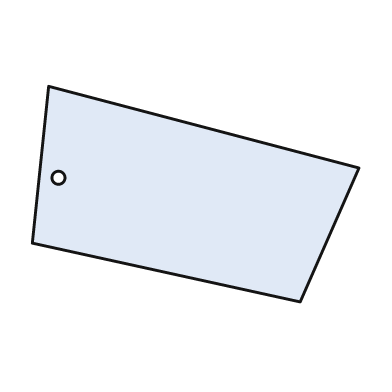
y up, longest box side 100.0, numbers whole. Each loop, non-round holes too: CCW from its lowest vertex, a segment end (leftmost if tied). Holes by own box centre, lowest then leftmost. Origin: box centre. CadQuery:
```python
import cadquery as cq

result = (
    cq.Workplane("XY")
    .moveTo(32.0, -33.0)
    .lineTo(50.0, 8.0)
    .lineTo(-45.0, 33.0)
    .lineTo(-50.0, -15.0)
    .close()
    .moveTo(-42.0, 5.0)
    .circle(2.0)
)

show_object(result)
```